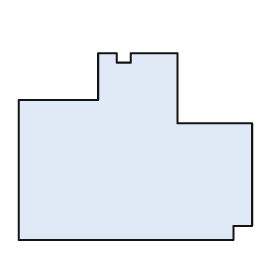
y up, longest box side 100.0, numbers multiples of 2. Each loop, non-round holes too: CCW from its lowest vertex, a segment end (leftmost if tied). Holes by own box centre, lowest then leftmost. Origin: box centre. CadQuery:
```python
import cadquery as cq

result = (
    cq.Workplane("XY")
    .moveTo(-50.0, -40.0)
    .lineTo(42.0, -40.0)
    .lineTo(42.0, -34.0)
    .lineTo(50.0, -34.0)
    .lineTo(50.0, 10.0)
    .lineTo(18.0, 10.0)
    .lineTo(18.0, 40.0)
    .lineTo(-2.0, 40.0)
    .lineTo(-2.0, 36.0)
    .lineTo(-8.0, 36.0)
    .lineTo(-8.0, 40.0)
    .lineTo(-16.0, 40.0)
    .lineTo(-16.0, 20.0)
    .lineTo(-50.0, 20.0)
    .close()
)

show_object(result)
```